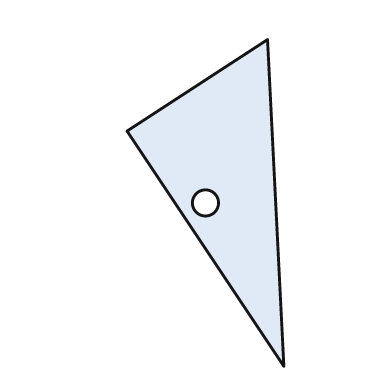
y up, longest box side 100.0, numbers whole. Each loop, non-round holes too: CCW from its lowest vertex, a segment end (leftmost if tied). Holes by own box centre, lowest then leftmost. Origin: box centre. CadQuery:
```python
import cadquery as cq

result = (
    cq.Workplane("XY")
    .moveTo(24.0, -50.0)
    .lineTo(19.0, 50.0)
    .lineTo(-24.0, 22.0)
    .close()
    .moveTo(0.0, 0.0)
    .circle(4.0)
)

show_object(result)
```